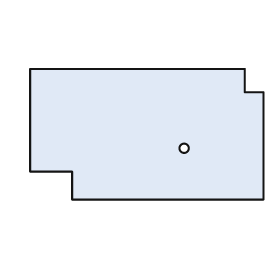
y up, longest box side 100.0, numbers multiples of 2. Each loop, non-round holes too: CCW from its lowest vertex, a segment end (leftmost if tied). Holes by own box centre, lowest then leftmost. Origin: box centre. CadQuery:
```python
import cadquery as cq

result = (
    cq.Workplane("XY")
    .moveTo(-32.0, -28.0)
    .lineTo(50.0, -28.0)
    .lineTo(50.0, 18.0)
    .lineTo(42.0, 18.0)
    .lineTo(42.0, 28.0)
    .lineTo(-50.0, 28.0)
    .lineTo(-50.0, -16.0)
    .lineTo(-32.0, -16.0)
    .close()
    .moveTo(16.0, -6.0)
    .circle(2.0)
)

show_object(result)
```